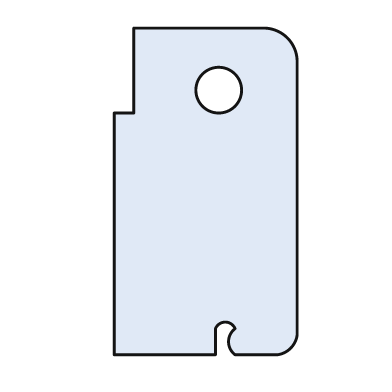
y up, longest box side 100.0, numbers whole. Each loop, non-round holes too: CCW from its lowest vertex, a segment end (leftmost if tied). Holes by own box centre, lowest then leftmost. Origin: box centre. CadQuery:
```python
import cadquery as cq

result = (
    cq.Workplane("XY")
    .moveTo(-28.0, -50.0)
    .lineTo(3.0, -50.0)
    .lineTo(3.0, -42.0)
    .threePointArc((6.0, -40.0), (9.0, -42.0))
    .threePointArc((7.0, -46.0), (9.0, -50.0))
    .lineTo(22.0, -50.0)
    .threePointArc((26.0, -48.0), (28.0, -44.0))
    .lineTo(28.0, 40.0)
    .threePointArc((25.0, 47.0), (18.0, 50.0))
    .lineTo(-22.0, 50.0)
    .lineTo(-22.0, 24.0)
    .lineTo(-28.0, 24.0)
    .close()
    .moveTo(4.0, 31.0)
    .circle(7.0)
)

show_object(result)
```